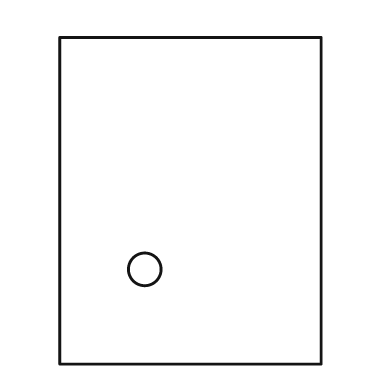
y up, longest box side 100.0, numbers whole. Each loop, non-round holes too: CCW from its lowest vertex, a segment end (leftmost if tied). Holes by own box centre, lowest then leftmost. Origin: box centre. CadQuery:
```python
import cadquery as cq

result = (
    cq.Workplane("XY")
    .moveTo(-40.0, -50.0)
    .lineTo(40.0, -50.0)
    .lineTo(40.0, 50.0)
    .lineTo(-40.0, 50.0)
    .close()
    .moveTo(-14.0, -21.0)
    .circle(5.0)
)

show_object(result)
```